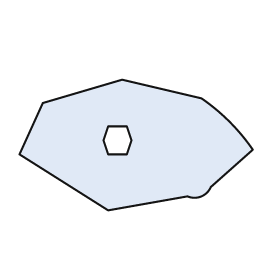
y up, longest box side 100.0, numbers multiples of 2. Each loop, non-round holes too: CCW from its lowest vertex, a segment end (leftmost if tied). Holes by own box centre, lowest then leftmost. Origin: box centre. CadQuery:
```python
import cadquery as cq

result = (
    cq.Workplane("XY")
    .moveTo(-12.0, -28.0)
    .lineTo(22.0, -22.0)
    .threePointArc((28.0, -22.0), (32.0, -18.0))
    .lineTo(50.0, -2.0)
    .threePointArc((40.0, 10.0), (28.0, 20.0))
    .lineTo(-6.0, 28.0)
    .lineTo(-40.0, 18.0)
    .lineTo(-50.0, -4.0)
    .close()
    .moveTo(-12.0, -4.0)
    .lineTo(-4.0, -4.0)
    .lineTo(-2.0, 2.0)
    .lineTo(-4.0, 8.0)
    .lineTo(-12.0, 8.0)
    .lineTo(-14.0, 2.0)
    .close()
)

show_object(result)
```